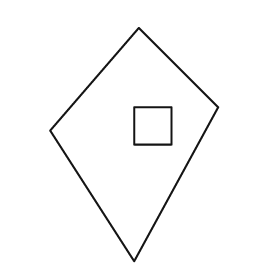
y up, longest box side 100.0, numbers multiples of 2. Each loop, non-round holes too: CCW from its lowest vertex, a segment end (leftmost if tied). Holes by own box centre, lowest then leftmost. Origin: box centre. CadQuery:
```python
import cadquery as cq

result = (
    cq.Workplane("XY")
    .moveTo(0.0, -50.0)
    .lineTo(36.0, 16.0)
    .lineTo(2.0, 50.0)
    .lineTo(-36.0, 6.0)
    .close()
    .moveTo(0.0, 0.0)
    .lineTo(16.0, 0.0)
    .lineTo(16.0, 16.0)
    .lineTo(0.0, 16.0)
    .close()
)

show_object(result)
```